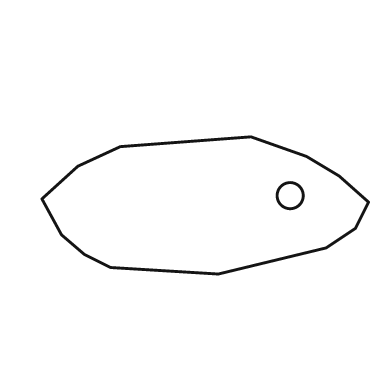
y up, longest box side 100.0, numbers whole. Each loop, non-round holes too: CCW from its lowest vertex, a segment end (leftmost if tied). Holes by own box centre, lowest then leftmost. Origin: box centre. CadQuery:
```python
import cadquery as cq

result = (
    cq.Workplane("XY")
    .moveTo(4.0, -21.0)
    .lineTo(37.0, -13.0)
    .lineTo(46.0, -7.0)
    .lineTo(50.0, 1.0)
    .lineTo(41.0, 9.0)
    .lineTo(31.0, 15.0)
    .lineTo(14.0, 21.0)
    .lineTo(-26.0, 18.0)
    .lineTo(-39.0, 12.0)
    .lineTo(-50.0, 2.0)
    .lineTo(-44.0, -9.0)
    .lineTo(-37.0, -15.0)
    .lineTo(-29.0, -19.0)
    .close()
    .moveTo(26.0, 3.0)
    .circle(4.0)
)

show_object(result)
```